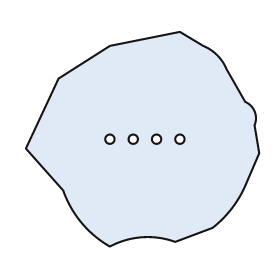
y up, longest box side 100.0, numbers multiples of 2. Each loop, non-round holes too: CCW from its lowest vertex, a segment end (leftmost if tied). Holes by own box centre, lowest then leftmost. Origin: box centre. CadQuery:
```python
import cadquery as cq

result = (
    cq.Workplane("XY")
    .moveTo(-14.0, -46.0)
    .threePointArc((0.0, -42.0), (14.0, -44.0))
    .lineTo(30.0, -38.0)
    .threePointArc((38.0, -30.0), (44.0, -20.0))
    .lineTo(50.0, -6.0)
    .lineTo(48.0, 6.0)
    .threePointArc((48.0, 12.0), (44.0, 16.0))
    .lineTo(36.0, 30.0)
    .threePointArc((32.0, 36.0), (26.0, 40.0))
    .lineTo(16.0, 46.0)
    .lineTo(-14.0, 40.0)
    .lineTo(-36.0, 26.0)
    .lineTo(-50.0, -4.0)
    .lineTo(-34.0, -22.0)
    .threePointArc((-26.0, -36.0), (-14.0, -46.0))
    .close()
    .moveTo(-14.0, 0.0)
    .circle(2.0)
    .moveTo(-4.0, 0.0)
    .circle(2.0)
    .moveTo(6.0, 0.0)
    .circle(2.0)
    .moveTo(16.0, 0.0)
    .circle(2.0)
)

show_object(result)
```